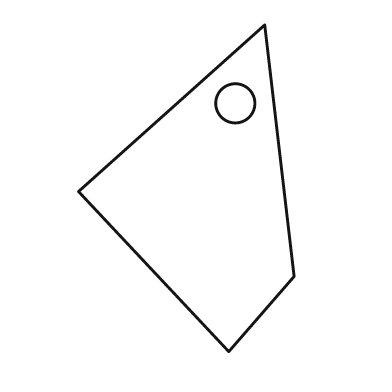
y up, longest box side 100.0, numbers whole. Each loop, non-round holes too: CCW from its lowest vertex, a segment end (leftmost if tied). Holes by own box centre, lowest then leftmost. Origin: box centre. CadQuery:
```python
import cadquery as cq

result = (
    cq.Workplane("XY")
    .moveTo(13.0, -50.0)
    .lineTo(33.0, -27.0)
    .lineTo(24.0, 50.0)
    .lineTo(-33.0, -1.0)
    .close()
    .moveTo(15.0, 26.0)
    .circle(6.0)
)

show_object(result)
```